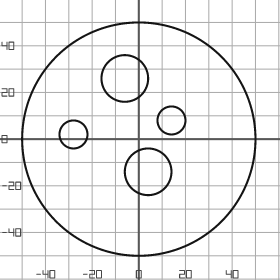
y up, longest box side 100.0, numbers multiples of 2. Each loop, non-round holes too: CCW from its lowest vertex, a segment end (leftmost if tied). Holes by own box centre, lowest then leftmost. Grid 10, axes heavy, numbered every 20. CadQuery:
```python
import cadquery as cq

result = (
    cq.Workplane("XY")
    .moveTo(0.0, 0.0)
    .circle(50.0)
    .moveTo(4.0, -14.0)
    .circle(10.0)
    .moveTo(-28.0, 2.0)
    .circle(6.0)
    .moveTo(14.0, 8.0)
    .circle(6.0)
    .moveTo(-6.0, 26.0)
    .circle(10.0)
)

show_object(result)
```